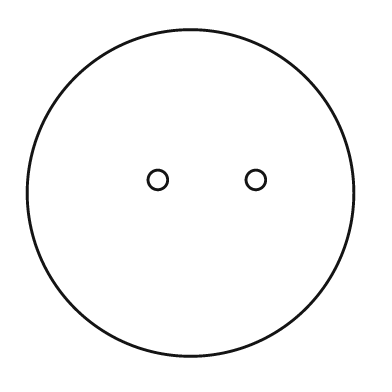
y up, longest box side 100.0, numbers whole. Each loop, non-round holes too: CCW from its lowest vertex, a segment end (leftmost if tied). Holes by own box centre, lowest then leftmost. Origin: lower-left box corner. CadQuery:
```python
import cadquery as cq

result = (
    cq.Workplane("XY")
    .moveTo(50.0, 50.0)
    .circle(50.0)
    .moveTo(40.0, 54.0)
    .circle(3.0)
    .moveTo(70.0, 54.0)
    .circle(3.0)
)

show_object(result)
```